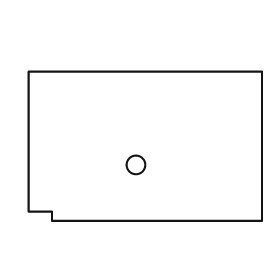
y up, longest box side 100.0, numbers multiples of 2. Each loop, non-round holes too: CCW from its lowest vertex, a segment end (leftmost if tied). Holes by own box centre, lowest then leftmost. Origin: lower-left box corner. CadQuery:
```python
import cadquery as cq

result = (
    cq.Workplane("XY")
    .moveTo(10.0, 0.0)
    .lineTo(100.0, 0.0)
    .lineTo(100.0, 64.0)
    .lineTo(0.0, 64.0)
    .lineTo(0.0, 4.0)
    .lineTo(10.0, 4.0)
    .close()
    .moveTo(46.0, 24.0)
    .circle(4.0)
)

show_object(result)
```